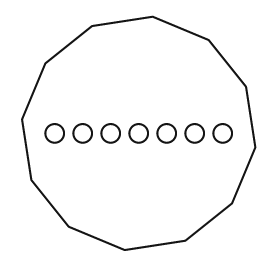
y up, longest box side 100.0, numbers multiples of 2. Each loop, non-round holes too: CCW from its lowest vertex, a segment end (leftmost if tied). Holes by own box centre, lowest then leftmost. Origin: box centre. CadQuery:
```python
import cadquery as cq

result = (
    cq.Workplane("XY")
    .moveTo(-6.0, -50.0)
    .lineTo(20.0, -46.0)
    .lineTo(40.0, -30.0)
    .lineTo(50.0, -6.0)
    .lineTo(46.0, 20.0)
    .lineTo(30.0, 40.0)
    .lineTo(6.0, 50.0)
    .lineTo(-20.0, 46.0)
    .lineTo(-40.0, 30.0)
    .lineTo(-50.0, 6.0)
    .lineTo(-46.0, -20.0)
    .lineTo(-30.0, -40.0)
    .close()
    .moveTo(-36.0, 0.0)
    .circle(4.0)
    .moveTo(-24.0, 0.0)
    .circle(4.0)
    .moveTo(-12.0, 0.0)
    .circle(4.0)
    .moveTo(0.0, 0.0)
    .circle(4.0)
    .moveTo(12.0, 0.0)
    .circle(4.0)
    .moveTo(24.0, 0.0)
    .circle(4.0)
    .moveTo(36.0, 0.0)
    .circle(4.0)
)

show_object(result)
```